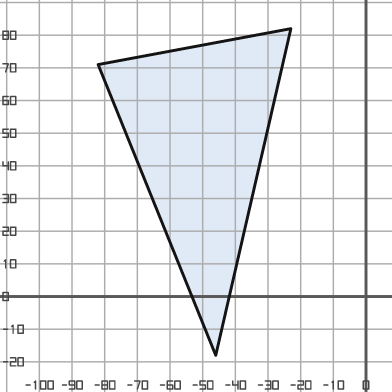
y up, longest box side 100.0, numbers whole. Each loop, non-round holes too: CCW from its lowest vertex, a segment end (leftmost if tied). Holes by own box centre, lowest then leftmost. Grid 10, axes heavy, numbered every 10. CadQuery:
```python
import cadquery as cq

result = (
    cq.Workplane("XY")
    .moveTo(-46.0, -18.0)
    .lineTo(-23.0, 82.0)
    .lineTo(-82.0, 71.0)
    .close()
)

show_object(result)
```